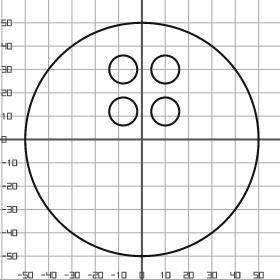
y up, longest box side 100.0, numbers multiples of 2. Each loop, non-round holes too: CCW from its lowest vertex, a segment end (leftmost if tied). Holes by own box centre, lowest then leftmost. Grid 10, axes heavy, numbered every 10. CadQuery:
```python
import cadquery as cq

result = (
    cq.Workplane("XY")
    .moveTo(0.0, 0.0)
    .circle(50.0)
    .moveTo(-8.0, 12.0)
    .circle(6.0)
    .moveTo(10.0, 12.0)
    .circle(6.0)
    .moveTo(-8.0, 30.0)
    .circle(6.0)
    .moveTo(10.0, 30.0)
    .circle(6.0)
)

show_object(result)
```